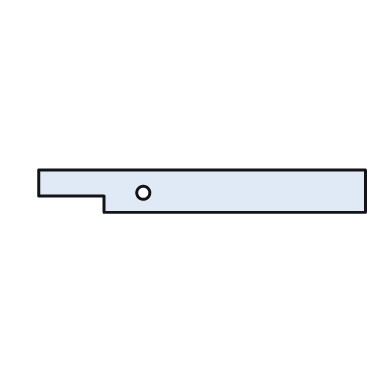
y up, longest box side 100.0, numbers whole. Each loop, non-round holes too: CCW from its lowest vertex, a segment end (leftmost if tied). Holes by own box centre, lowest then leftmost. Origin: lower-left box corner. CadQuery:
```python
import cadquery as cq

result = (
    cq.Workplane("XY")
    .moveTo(20.0, 0.0)
    .lineTo(100.0, 0.0)
    .lineTo(100.0, 13.0)
    .lineTo(0.0, 13.0)
    .lineTo(0.0, 5.0)
    .lineTo(20.0, 5.0)
    .close()
    .moveTo(32.0, 6.0)
    .circle(2.0)
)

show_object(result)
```